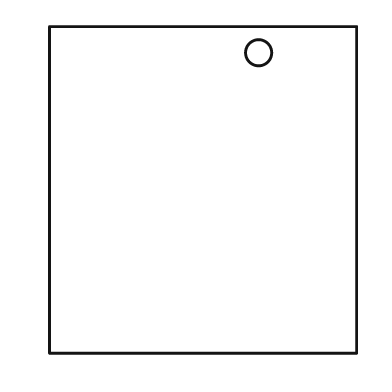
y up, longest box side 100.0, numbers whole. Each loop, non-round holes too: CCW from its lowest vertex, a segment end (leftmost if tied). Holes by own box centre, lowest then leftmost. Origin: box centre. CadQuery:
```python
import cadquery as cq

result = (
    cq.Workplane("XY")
    .moveTo(-47.0, -50.0)
    .lineTo(47.0, -50.0)
    .lineTo(47.0, 50.0)
    .lineTo(-47.0, 50.0)
    .close()
    .moveTo(17.0, 42.0)
    .circle(4.0)
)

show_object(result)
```